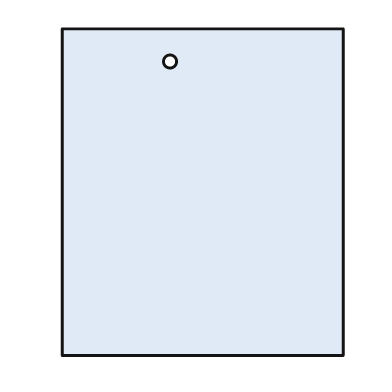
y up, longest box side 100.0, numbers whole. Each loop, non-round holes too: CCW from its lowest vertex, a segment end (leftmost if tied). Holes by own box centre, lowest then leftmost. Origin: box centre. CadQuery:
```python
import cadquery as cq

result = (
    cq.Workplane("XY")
    .moveTo(-43.0, -50.0)
    .lineTo(43.0, -50.0)
    .lineTo(43.0, 50.0)
    .lineTo(-43.0, 50.0)
    .close()
    .moveTo(-10.0, 40.0)
    .circle(2.0)
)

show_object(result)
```